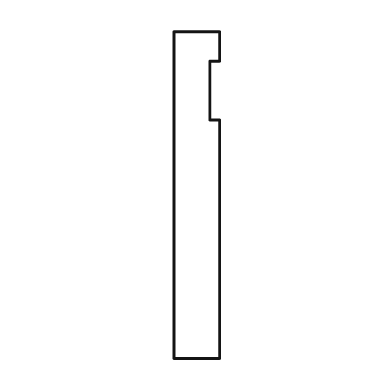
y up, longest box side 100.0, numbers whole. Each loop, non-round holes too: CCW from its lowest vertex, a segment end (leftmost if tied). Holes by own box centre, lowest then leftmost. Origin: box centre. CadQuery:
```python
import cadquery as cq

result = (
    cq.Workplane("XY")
    .moveTo(-7.0, -50.0)
    .lineTo(7.0, -50.0)
    .lineTo(7.0, 23.0)
    .lineTo(4.0, 23.0)
    .lineTo(4.0, 41.0)
    .lineTo(7.0, 41.0)
    .lineTo(7.0, 50.0)
    .lineTo(-7.0, 50.0)
    .close()
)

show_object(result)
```